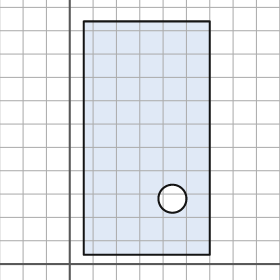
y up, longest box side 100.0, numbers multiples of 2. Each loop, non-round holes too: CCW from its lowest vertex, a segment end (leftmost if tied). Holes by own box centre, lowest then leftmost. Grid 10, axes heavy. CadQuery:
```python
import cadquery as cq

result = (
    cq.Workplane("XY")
    .moveTo(6.0, 4.0)
    .lineTo(60.0, 4.0)
    .lineTo(60.0, 104.0)
    .lineTo(6.0, 104.0)
    .close()
    .moveTo(44.0, 28.0)
    .circle(6.0)
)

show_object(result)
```